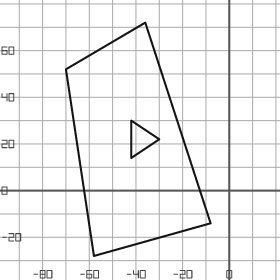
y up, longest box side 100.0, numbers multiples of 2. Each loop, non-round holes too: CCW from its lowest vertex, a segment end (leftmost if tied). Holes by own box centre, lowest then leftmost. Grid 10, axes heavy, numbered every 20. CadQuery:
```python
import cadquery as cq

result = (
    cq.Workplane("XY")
    .moveTo(-58.0, -28.0)
    .lineTo(-8.0, -14.0)
    .lineTo(-36.0, 72.0)
    .lineTo(-70.0, 52.0)
    .close()
    .moveTo(-42.0, 14.0)
    .lineTo(-30.0, 22.0)
    .lineTo(-42.0, 30.0)
    .close()
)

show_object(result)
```